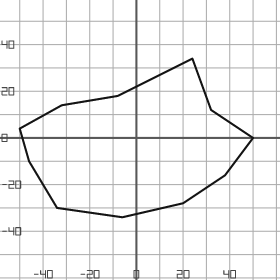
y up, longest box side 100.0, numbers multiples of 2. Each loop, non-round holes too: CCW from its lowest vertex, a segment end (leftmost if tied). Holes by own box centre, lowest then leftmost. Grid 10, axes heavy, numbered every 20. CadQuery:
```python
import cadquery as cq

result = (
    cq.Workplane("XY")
    .moveTo(-6.0, -34.0)
    .lineTo(20.0, -28.0)
    .lineTo(38.0, -16.0)
    .lineTo(50.0, 0.0)
    .lineTo(32.0, 12.0)
    .lineTo(24.0, 34.0)
    .lineTo(-8.0, 18.0)
    .lineTo(-32.0, 14.0)
    .lineTo(-50.0, 4.0)
    .lineTo(-46.0, -10.0)
    .lineTo(-34.0, -30.0)
    .close()
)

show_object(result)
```